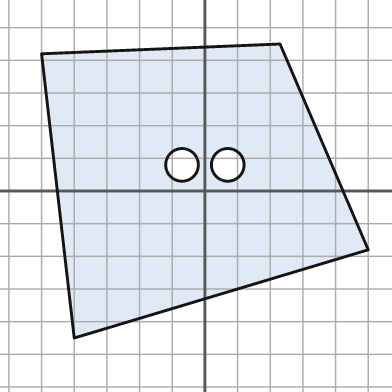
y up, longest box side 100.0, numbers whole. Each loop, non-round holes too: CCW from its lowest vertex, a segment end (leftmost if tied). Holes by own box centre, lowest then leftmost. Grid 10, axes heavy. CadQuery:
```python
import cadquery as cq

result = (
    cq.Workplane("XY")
    .moveTo(-40.0, -45.0)
    .lineTo(50.0, -18.0)
    .lineTo(23.0, 45.0)
    .lineTo(-50.0, 42.0)
    .close()
    .moveTo(-7.0, 8.0)
    .circle(5.0)
    .moveTo(7.0, 8.0)
    .circle(5.0)
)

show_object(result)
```